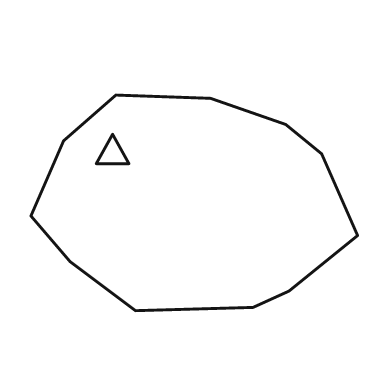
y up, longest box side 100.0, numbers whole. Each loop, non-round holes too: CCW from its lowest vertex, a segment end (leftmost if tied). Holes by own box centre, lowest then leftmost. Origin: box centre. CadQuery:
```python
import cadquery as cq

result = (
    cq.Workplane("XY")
    .moveTo(-18.0, -33.0)
    .lineTo(18.0, -32.0)
    .lineTo(29.0, -27.0)
    .lineTo(50.0, -10.0)
    .lineTo(39.0, 15.0)
    .lineTo(28.0, 24.0)
    .lineTo(5.0, 32.0)
    .lineTo(-24.0, 33.0)
    .lineTo(-40.0, 19.0)
    .lineTo(-50.0, -4.0)
    .lineTo(-38.0, -18.0)
    .close()
    .moveTo(-30.0, 12.0)
    .lineTo(-20.0, 12.0)
    .lineTo(-25.0, 21.0)
    .close()
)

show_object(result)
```